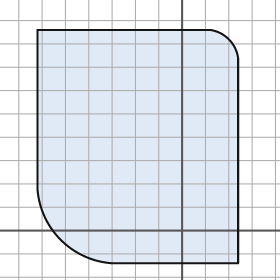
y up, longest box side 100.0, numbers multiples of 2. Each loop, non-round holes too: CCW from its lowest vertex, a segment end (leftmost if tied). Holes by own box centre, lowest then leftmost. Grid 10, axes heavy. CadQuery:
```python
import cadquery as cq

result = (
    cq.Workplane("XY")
    .moveTo(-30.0, -14.0)
    .lineTo(24.0, -14.0)
    .lineTo(24.0, 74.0)
    .threePointArc((20.0, 82.0), (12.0, 86.0))
    .lineTo(-62.0, 86.0)
    .lineTo(-62.0, 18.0)
    .threePointArc((-52.0, -4.0), (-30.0, -14.0))
    .close()
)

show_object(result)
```